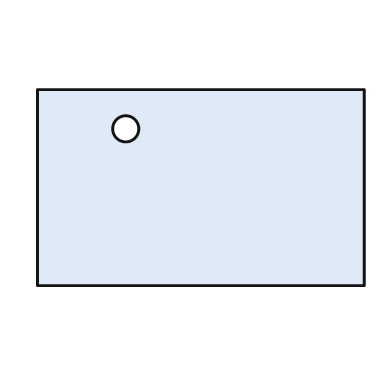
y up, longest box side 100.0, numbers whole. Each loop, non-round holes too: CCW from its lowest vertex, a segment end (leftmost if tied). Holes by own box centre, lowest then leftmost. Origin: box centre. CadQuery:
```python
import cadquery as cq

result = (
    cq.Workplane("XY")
    .moveTo(-50.0, -30.0)
    .lineTo(50.0, -30.0)
    .lineTo(50.0, 30.0)
    .lineTo(-50.0, 30.0)
    .close()
    .moveTo(-23.0, 18.0)
    .circle(4.0)
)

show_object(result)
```